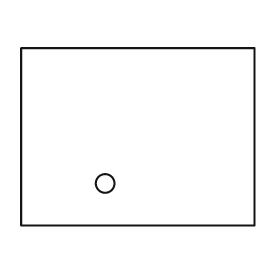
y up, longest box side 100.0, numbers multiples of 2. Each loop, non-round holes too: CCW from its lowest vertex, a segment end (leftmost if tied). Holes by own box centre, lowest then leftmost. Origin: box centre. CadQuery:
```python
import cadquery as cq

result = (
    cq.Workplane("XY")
    .moveTo(-50.0, -38.0)
    .lineTo(50.0, -38.0)
    .lineTo(50.0, 38.0)
    .lineTo(-50.0, 38.0)
    .close()
    .moveTo(-14.0, -20.0)
    .circle(4.0)
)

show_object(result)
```